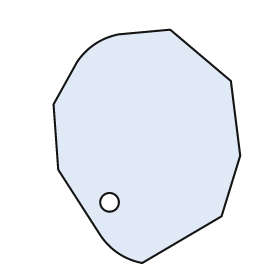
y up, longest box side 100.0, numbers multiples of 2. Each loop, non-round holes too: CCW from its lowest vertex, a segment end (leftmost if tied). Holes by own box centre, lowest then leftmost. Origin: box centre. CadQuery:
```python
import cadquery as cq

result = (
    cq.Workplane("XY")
    .moveTo(-2.0, -50.0)
    .lineTo(32.0, -30.0)
    .lineTo(40.0, -4.0)
    .lineTo(36.0, 28.0)
    .lineTo(10.0, 50.0)
    .lineTo(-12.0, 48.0)
    .threePointArc((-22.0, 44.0), (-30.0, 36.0))
    .lineTo(-40.0, 18.0)
    .lineTo(-38.0, -10.0)
    .lineTo(-20.0, -38.0)
    .threePointArc((-12.0, -46.0), (-2.0, -50.0))
    .close()
    .moveTo(-16.0, -24.0)
    .circle(4.0)
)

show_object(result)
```